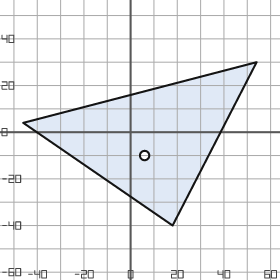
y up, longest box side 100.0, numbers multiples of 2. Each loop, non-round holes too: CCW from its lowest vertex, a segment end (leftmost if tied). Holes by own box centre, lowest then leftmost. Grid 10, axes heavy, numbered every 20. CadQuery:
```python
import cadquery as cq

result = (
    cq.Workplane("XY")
    .moveTo(18.0, -40.0)
    .lineTo(54.0, 30.0)
    .lineTo(-46.0, 4.0)
    .close()
    .moveTo(6.0, -10.0)
    .circle(2.0)
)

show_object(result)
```